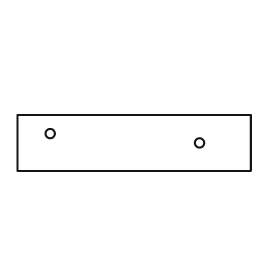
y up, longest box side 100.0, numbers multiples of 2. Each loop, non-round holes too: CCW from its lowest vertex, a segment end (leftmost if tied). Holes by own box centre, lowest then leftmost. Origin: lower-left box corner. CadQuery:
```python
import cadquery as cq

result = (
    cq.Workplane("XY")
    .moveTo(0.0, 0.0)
    .lineTo(100.0, 0.0)
    .lineTo(100.0, 24.0)
    .lineTo(0.0, 24.0)
    .close()
    .moveTo(78.0, 12.0)
    .circle(2.0)
    .moveTo(14.0, 16.0)
    .circle(2.0)
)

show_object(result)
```